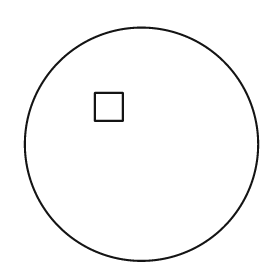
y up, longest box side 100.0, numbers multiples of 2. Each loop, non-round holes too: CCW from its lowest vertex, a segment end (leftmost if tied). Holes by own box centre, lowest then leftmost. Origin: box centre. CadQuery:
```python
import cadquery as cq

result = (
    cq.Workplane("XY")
    .moveTo(0.0, 0.0)
    .circle(50.0)
    .moveTo(-20.0, 10.0)
    .lineTo(-8.0, 10.0)
    .lineTo(-8.0, 22.0)
    .lineTo(-20.0, 22.0)
    .close()
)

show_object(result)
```